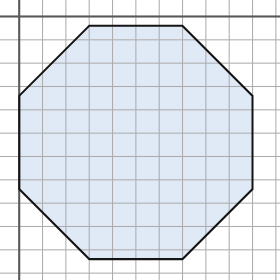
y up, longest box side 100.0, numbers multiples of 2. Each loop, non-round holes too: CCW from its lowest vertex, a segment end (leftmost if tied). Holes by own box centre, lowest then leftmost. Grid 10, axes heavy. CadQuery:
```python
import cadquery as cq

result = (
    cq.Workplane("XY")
    .moveTo(30.0, -104.0)
    .lineTo(70.0, -104.0)
    .lineTo(100.0, -74.0)
    .lineTo(100.0, -34.0)
    .lineTo(70.0, -4.0)
    .lineTo(30.0, -4.0)
    .lineTo(0.0, -34.0)
    .lineTo(0.0, -74.0)
    .close()
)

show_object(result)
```